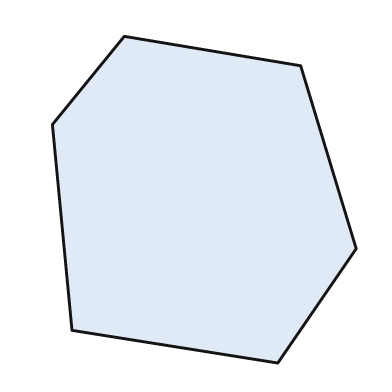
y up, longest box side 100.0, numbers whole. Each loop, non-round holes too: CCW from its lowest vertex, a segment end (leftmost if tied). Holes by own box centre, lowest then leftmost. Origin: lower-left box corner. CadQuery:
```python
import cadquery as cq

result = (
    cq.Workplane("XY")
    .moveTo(69.0, 0.0)
    .lineTo(93.0, 35.0)
    .lineTo(76.0, 91.0)
    .lineTo(22.0, 100.0)
    .lineTo(0.0, 73.0)
    .lineTo(6.0, 10.0)
    .close()
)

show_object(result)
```